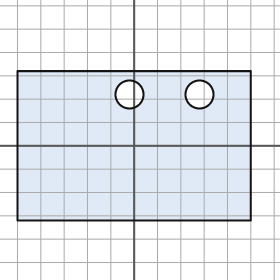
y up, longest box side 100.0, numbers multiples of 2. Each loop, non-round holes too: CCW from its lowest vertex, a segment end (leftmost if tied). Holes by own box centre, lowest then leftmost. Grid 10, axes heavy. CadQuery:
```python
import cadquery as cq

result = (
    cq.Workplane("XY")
    .moveTo(-50.0, -32.0)
    .lineTo(50.0, -32.0)
    .lineTo(50.0, 32.0)
    .lineTo(-50.0, 32.0)
    .close()
    .moveTo(-2.0, 22.0)
    .circle(6.0)
    .moveTo(28.0, 22.0)
    .circle(6.0)
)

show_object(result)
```